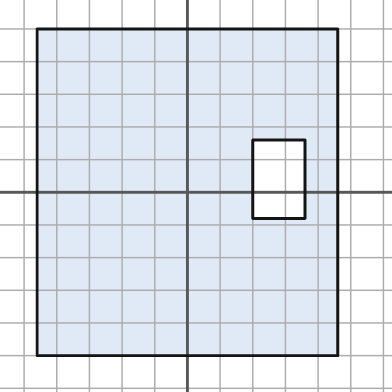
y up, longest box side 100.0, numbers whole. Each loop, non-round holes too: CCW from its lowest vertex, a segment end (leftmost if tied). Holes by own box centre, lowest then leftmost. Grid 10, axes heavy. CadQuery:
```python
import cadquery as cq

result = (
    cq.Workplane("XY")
    .moveTo(-46.0, -50.0)
    .lineTo(46.0, -50.0)
    .lineTo(46.0, 50.0)
    .lineTo(-46.0, 50.0)
    .close()
    .moveTo(20.0, -8.0)
    .lineTo(36.0, -8.0)
    .lineTo(36.0, 16.0)
    .lineTo(20.0, 16.0)
    .close()
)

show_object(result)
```